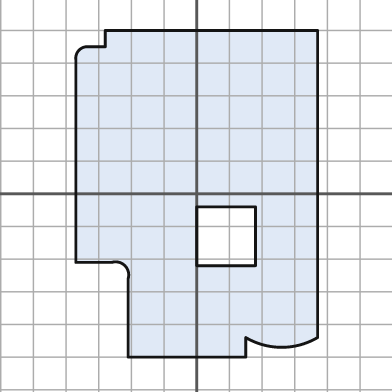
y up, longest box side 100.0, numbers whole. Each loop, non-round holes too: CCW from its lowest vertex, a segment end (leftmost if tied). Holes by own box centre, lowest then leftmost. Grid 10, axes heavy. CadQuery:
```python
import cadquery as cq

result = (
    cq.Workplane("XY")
    .moveTo(-21.0, -50.0)
    .lineTo(15.0, -50.0)
    .lineTo(15.0, -44.0)
    .threePointArc((26.0, -47.0), (37.0, -44.0))
    .lineTo(37.0, 50.0)
    .lineTo(-28.0, 50.0)
    .lineTo(-28.0, 45.0)
    .lineTo(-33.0, 45.0)
    .threePointArc((-36.0, 44.0), (-37.0, 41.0))
    .lineTo(-37.0, -21.0)
    .lineTo(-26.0, -21.0)
    .threePointArc((-22.0, -22.0), (-21.0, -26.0))
    .close()
    .moveTo(0.0, -22.0)
    .lineTo(18.0, -22.0)
    .lineTo(18.0, -4.0)
    .lineTo(0.0, -4.0)
    .close()
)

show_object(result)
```